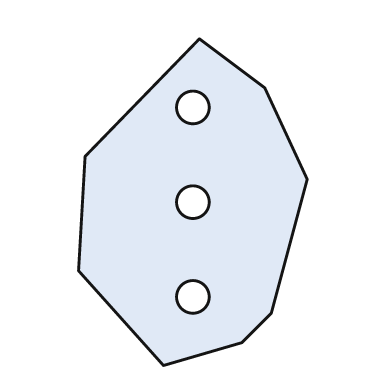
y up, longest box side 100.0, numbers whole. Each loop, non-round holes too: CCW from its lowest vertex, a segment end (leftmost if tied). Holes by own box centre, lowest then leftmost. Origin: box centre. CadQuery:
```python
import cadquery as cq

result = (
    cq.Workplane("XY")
    .moveTo(-9.0, -50.0)
    .lineTo(15.0, -43.0)
    .lineTo(24.0, -34.0)
    .lineTo(35.0, 7.0)
    .lineTo(22.0, 35.0)
    .lineTo(2.0, 50.0)
    .lineTo(-33.0, 14.0)
    .lineTo(-35.0, -21.0)
    .close()
    .moveTo(0.0, -29.0)
    .circle(5.0)
    .moveTo(0.0, 0.0)
    .circle(5.0)
    .moveTo(0.0, 29.0)
    .circle(5.0)
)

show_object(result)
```